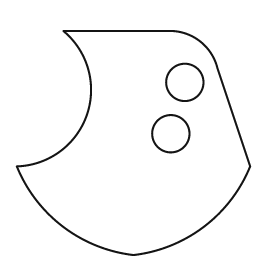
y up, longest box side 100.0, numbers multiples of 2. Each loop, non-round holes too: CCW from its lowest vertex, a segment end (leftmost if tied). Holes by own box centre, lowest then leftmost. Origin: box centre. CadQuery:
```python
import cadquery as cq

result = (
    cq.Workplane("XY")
    .moveTo(0.0, -48.0)
    .threePointArc((30.0, -36.0), (50.0, -10.0))
    .lineTo(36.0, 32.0)
    .threePointArc((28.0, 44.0), (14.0, 48.0))
    .lineTo(-30.0, 48.0)
    .threePointArc((-20.0, 12.0), (-50.0, -10.0))
    .threePointArc((-30.0, -36.0), (0.0, -48.0))
    .close()
    .moveTo(16.0, 4.0)
    .circle(8.0)
    .moveTo(22.0, 26.0)
    .circle(8.0)
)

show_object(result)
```